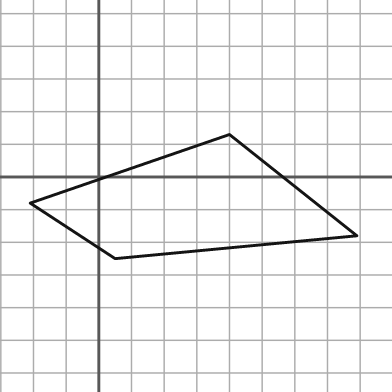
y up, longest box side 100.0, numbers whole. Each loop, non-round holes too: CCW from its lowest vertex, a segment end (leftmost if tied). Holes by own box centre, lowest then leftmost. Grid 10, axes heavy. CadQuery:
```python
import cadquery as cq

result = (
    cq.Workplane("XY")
    .moveTo(5.0, -25.0)
    .lineTo(79.0, -18.0)
    .lineTo(40.0, 13.0)
    .lineTo(-21.0, -8.0)
    .close()
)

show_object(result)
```